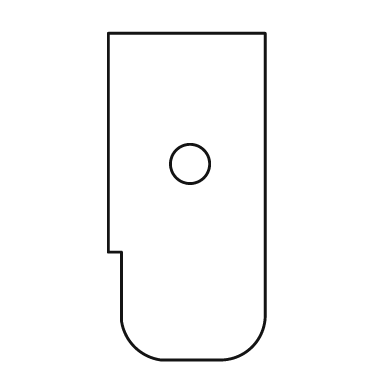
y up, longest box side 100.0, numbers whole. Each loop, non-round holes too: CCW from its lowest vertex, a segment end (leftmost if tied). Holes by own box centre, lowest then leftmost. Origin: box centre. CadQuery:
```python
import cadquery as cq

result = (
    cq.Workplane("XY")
    .moveTo(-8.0, -50.0)
    .lineTo(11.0, -50.0)
    .threePointArc((20.0, -46.0), (24.0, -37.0))
    .lineTo(24.0, 50.0)
    .lineTo(-24.0, 50.0)
    .lineTo(-24.0, -17.0)
    .lineTo(-20.0, -17.0)
    .lineTo(-20.0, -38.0)
    .threePointArc((-16.0, -46.0), (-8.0, -50.0))
    .close()
    .moveTo(1.0, 10.0)
    .circle(6.0)
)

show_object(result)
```